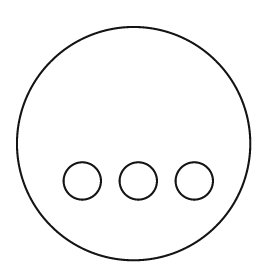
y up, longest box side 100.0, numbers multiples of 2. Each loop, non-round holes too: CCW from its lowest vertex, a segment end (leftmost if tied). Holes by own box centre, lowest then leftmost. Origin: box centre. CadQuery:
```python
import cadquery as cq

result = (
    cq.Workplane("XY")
    .moveTo(0.0, 0.0)
    .circle(50.0)
    .moveTo(-22.0, -16.0)
    .circle(8.0)
    .moveTo(2.0, -16.0)
    .circle(8.0)
    .moveTo(26.0, -16.0)
    .circle(8.0)
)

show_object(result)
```